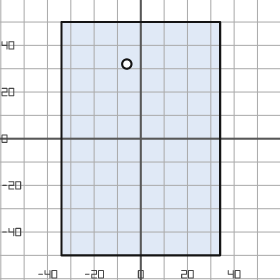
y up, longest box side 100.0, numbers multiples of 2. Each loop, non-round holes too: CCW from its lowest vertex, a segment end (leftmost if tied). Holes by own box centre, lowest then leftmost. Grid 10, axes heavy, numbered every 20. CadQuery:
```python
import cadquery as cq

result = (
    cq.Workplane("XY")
    .moveTo(-34.0, -50.0)
    .lineTo(34.0, -50.0)
    .lineTo(34.0, 50.0)
    .lineTo(-34.0, 50.0)
    .close()
    .moveTo(-6.0, 32.0)
    .circle(2.0)
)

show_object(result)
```